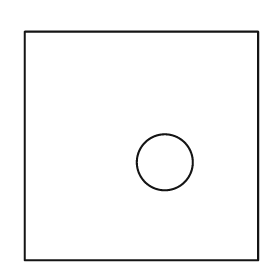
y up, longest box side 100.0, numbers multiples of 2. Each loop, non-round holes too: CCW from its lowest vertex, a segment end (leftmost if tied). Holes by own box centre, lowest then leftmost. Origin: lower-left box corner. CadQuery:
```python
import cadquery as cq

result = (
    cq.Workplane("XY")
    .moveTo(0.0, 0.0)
    .lineTo(100.0, 0.0)
    .lineTo(100.0, 98.0)
    .lineTo(0.0, 98.0)
    .close()
    .moveTo(60.0, 42.0)
    .circle(12.0)
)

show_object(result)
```